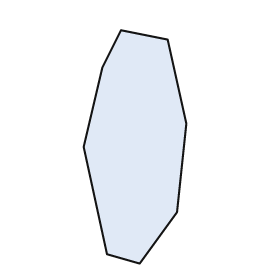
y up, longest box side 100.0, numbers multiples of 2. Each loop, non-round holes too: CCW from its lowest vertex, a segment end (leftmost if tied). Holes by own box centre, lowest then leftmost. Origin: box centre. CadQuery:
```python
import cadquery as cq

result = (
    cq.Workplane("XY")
    .moveTo(2.0, -50.0)
    .lineTo(18.0, -28.0)
    .lineTo(22.0, 10.0)
    .lineTo(14.0, 46.0)
    .lineTo(-6.0, 50.0)
    .lineTo(-14.0, 34.0)
    .lineTo(-22.0, 0.0)
    .lineTo(-12.0, -46.0)
    .close()
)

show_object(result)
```